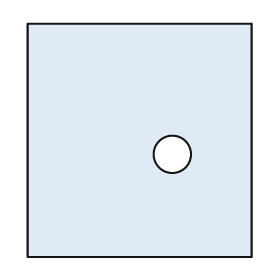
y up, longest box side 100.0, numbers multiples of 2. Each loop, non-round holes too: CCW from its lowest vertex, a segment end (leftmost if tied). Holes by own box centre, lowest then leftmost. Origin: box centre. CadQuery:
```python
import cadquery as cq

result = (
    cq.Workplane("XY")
    .moveTo(-48.0, -50.0)
    .lineTo(48.0, -50.0)
    .lineTo(48.0, 50.0)
    .lineTo(-48.0, 50.0)
    .close()
    .moveTo(14.0, -6.0)
    .circle(8.0)
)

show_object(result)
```